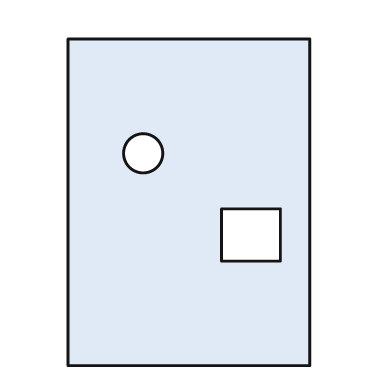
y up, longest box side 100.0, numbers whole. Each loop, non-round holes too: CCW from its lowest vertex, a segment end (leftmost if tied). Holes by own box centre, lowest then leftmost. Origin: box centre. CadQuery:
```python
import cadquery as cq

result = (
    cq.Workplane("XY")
    .moveTo(-37.0, -50.0)
    .lineTo(37.0, -50.0)
    .lineTo(37.0, 50.0)
    .lineTo(-37.0, 50.0)
    .close()
    .moveTo(10.0, -18.0)
    .lineTo(28.0, -18.0)
    .lineTo(28.0, -2.0)
    .lineTo(10.0, -2.0)
    .close()
    .moveTo(-14.0, 15.0)
    .circle(6.0)
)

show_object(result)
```